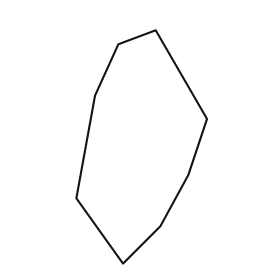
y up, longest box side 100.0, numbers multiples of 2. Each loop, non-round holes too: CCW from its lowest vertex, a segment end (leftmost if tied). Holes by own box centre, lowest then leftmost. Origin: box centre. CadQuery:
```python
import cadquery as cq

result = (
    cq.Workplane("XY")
    .moveTo(-8.0, -50.0)
    .lineTo(8.0, -34.0)
    .lineTo(20.0, -12.0)
    .lineTo(28.0, 12.0)
    .lineTo(6.0, 50.0)
    .lineTo(-10.0, 44.0)
    .lineTo(-20.0, 22.0)
    .lineTo(-28.0, -22.0)
    .close()
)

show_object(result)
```